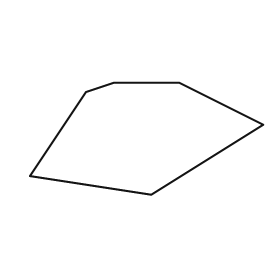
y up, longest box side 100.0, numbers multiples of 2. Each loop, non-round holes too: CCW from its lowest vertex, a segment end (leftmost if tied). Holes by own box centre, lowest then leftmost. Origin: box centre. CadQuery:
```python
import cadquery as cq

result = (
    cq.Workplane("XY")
    .moveTo(2.0, -24.0)
    .lineTo(50.0, 6.0)
    .lineTo(14.0, 24.0)
    .lineTo(-14.0, 24.0)
    .lineTo(-26.0, 20.0)
    .lineTo(-50.0, -16.0)
    .close()
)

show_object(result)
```